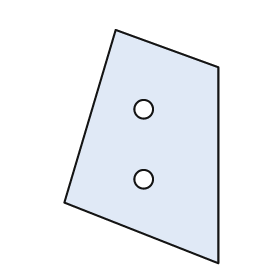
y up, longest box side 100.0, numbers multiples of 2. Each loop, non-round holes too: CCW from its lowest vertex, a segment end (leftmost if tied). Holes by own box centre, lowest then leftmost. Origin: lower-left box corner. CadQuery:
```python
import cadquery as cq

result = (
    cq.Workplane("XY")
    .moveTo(66.0, 0.0)
    .lineTo(66.0, 84.0)
    .lineTo(22.0, 100.0)
    .lineTo(0.0, 26.0)
    .close()
    .moveTo(34.0, 36.0)
    .circle(4.0)
    .moveTo(34.0, 66.0)
    .circle(4.0)
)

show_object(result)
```